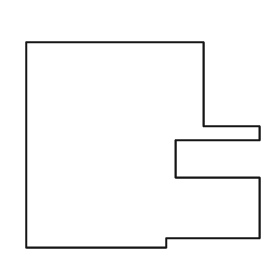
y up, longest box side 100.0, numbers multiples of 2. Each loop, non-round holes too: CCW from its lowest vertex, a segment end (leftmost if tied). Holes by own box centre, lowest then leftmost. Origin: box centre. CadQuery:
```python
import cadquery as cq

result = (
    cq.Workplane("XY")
    .moveTo(-50.0, -44.0)
    .lineTo(10.0, -44.0)
    .lineTo(10.0, -40.0)
    .lineTo(50.0, -40.0)
    .lineTo(50.0, -14.0)
    .lineTo(14.0, -14.0)
    .lineTo(14.0, 2.0)
    .lineTo(50.0, 2.0)
    .lineTo(50.0, 8.0)
    .lineTo(26.0, 8.0)
    .lineTo(26.0, 44.0)
    .lineTo(-50.0, 44.0)
    .close()
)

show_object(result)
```